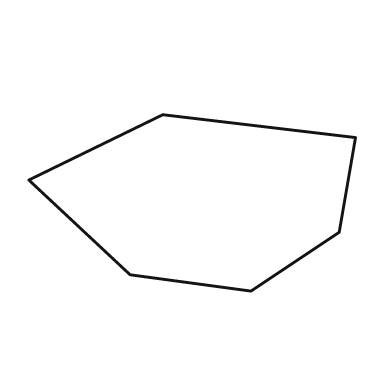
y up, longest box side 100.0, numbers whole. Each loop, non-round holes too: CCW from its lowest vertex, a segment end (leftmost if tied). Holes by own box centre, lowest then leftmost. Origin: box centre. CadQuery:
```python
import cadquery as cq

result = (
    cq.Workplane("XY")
    .moveTo(18.0, -27.0)
    .lineTo(45.0, -9.0)
    .lineTo(50.0, 20.0)
    .lineTo(-9.0, 27.0)
    .lineTo(-50.0, 7.0)
    .lineTo(-19.0, -22.0)
    .close()
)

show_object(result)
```